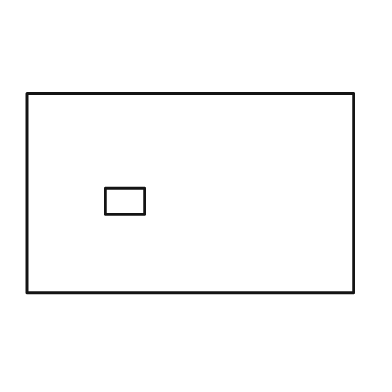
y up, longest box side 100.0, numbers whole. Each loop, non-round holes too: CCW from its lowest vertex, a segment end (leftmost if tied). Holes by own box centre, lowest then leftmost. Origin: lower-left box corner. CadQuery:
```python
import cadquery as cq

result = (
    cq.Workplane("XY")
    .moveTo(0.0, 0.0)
    .lineTo(100.0, 0.0)
    .lineTo(100.0, 61.0)
    .lineTo(0.0, 61.0)
    .close()
    .moveTo(24.0, 24.0)
    .lineTo(36.0, 24.0)
    .lineTo(36.0, 32.0)
    .lineTo(24.0, 32.0)
    .close()
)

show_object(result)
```